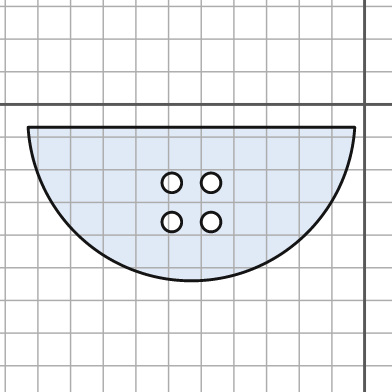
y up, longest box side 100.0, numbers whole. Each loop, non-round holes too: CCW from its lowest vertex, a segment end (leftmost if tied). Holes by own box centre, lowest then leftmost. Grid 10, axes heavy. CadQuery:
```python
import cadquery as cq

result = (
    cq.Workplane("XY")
    .moveTo(-103.0, -7.0)
    .threePointArc((-53.0, -54.0), (-3.0, -7.0))
    .close()
    .moveTo(-59.0, -36.0)
    .circle(3.0)
    .moveTo(-47.0, -36.0)
    .circle(3.0)
    .moveTo(-59.0, -24.0)
    .circle(3.0)
    .moveTo(-47.0, -24.0)
    .circle(3.0)
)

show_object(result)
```